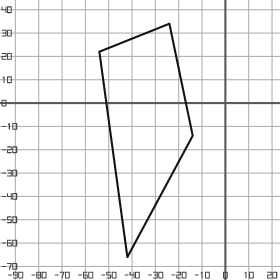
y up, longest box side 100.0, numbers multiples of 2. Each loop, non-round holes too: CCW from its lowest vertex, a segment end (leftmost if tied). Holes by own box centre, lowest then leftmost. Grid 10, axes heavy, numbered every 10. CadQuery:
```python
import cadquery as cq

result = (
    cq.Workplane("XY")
    .moveTo(-42.0, -66.0)
    .lineTo(-14.0, -14.0)
    .lineTo(-24.0, 34.0)
    .lineTo(-54.0, 22.0)
    .close()
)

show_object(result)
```